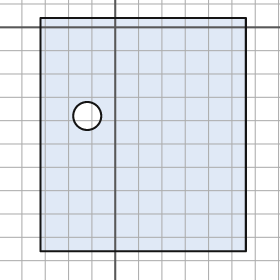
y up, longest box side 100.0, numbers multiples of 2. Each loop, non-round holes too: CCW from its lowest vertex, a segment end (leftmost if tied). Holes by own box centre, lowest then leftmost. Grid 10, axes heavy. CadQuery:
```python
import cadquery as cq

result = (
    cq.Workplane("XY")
    .moveTo(-32.0, -96.0)
    .lineTo(56.0, -96.0)
    .lineTo(56.0, 4.0)
    .lineTo(-32.0, 4.0)
    .close()
    .moveTo(-12.0, -38.0)
    .circle(6.0)
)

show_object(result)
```